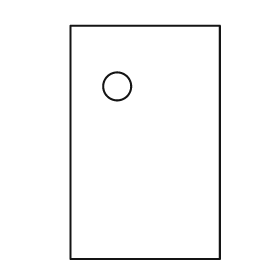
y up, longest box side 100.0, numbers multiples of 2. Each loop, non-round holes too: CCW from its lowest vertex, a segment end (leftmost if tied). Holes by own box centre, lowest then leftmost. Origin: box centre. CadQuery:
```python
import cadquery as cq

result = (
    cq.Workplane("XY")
    .moveTo(-32.0, -50.0)
    .lineTo(32.0, -50.0)
    .lineTo(32.0, 50.0)
    .lineTo(-32.0, 50.0)
    .close()
    .moveTo(-12.0, 24.0)
    .circle(6.0)
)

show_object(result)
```